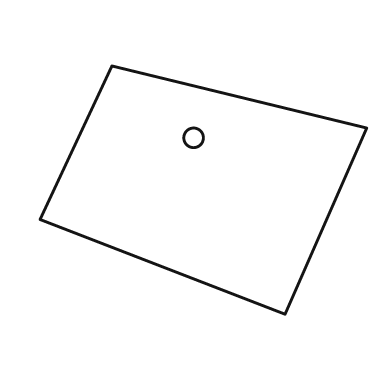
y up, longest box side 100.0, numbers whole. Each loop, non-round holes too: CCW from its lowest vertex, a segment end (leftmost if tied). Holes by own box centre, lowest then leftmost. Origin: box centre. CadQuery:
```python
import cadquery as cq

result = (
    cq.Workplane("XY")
    .moveTo(25.0, -38.0)
    .lineTo(50.0, 19.0)
    .lineTo(-28.0, 38.0)
    .lineTo(-50.0, -9.0)
    .close()
    .moveTo(-3.0, 16.0)
    .circle(3.0)
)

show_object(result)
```